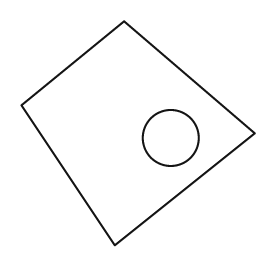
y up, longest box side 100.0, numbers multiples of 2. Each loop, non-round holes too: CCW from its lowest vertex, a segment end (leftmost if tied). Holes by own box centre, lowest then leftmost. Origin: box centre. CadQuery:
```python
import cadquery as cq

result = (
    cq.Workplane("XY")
    .moveTo(-10.0, -48.0)
    .lineTo(50.0, 0.0)
    .lineTo(-6.0, 48.0)
    .lineTo(-50.0, 12.0)
    .close()
    .moveTo(14.0, -2.0)
    .circle(12.0)
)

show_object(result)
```